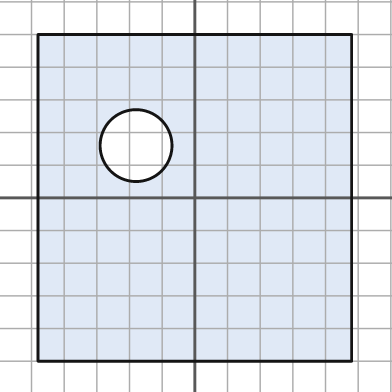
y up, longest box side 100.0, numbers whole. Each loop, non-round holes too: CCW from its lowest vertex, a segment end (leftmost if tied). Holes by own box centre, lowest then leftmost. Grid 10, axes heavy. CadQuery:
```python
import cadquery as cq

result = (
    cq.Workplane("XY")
    .moveTo(-48.0, -50.0)
    .lineTo(48.0, -50.0)
    .lineTo(48.0, 50.0)
    .lineTo(-48.0, 50.0)
    .close()
    .moveTo(-18.0, 16.0)
    .circle(11.0)
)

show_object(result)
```